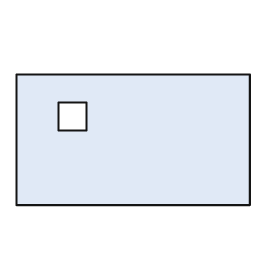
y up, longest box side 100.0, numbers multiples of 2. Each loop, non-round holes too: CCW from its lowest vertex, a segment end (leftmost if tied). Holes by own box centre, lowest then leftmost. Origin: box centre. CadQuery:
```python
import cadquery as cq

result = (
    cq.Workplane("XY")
    .moveTo(-50.0, -28.0)
    .lineTo(50.0, -28.0)
    .lineTo(50.0, 28.0)
    .lineTo(-50.0, 28.0)
    .close()
    .moveTo(-32.0, 4.0)
    .lineTo(-20.0, 4.0)
    .lineTo(-20.0, 16.0)
    .lineTo(-32.0, 16.0)
    .close()
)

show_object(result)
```